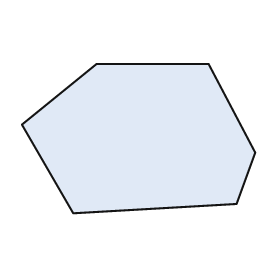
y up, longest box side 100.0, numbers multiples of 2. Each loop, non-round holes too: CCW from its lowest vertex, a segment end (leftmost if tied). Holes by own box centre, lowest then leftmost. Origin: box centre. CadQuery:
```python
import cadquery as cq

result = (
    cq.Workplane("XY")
    .moveTo(-28.0, -32.0)
    .lineTo(42.0, -28.0)
    .lineTo(50.0, -6.0)
    .lineTo(30.0, 32.0)
    .lineTo(-18.0, 32.0)
    .lineTo(-50.0, 6.0)
    .close()
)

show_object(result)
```